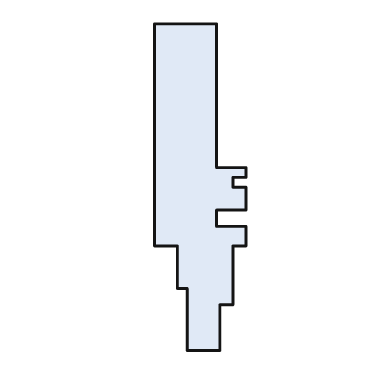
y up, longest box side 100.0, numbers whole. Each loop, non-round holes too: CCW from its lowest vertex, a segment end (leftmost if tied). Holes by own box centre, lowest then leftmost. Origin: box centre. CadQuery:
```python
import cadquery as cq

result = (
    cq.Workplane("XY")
    .moveTo(-4.0, -50.0)
    .lineTo(6.0, -50.0)
    .lineTo(6.0, -36.0)
    .lineTo(10.0, -36.0)
    .lineTo(10.0, -18.0)
    .lineTo(14.0, -18.0)
    .lineTo(14.0, -12.0)
    .lineTo(5.0, -12.0)
    .lineTo(5.0, -7.0)
    .lineTo(14.0, -7.0)
    .lineTo(14.0, 0.0)
    .lineTo(10.0, 0.0)
    .lineTo(10.0, 3.0)
    .lineTo(14.0, 3.0)
    .lineTo(14.0, 6.0)
    .lineTo(5.0, 6.0)
    .lineTo(5.0, 50.0)
    .lineTo(-14.0, 50.0)
    .lineTo(-14.0, -18.0)
    .lineTo(-7.0, -18.0)
    .lineTo(-7.0, -31.0)
    .lineTo(-4.0, -31.0)
    .close()
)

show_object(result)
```